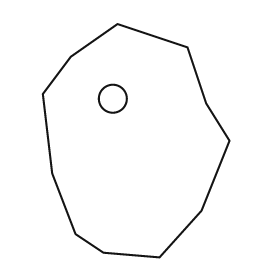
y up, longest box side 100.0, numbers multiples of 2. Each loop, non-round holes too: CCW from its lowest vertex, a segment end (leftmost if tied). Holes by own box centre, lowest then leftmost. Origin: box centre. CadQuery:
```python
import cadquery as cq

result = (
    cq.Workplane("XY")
    .moveTo(10.0, -50.0)
    .lineTo(28.0, -30.0)
    .lineTo(40.0, 0.0)
    .lineTo(30.0, 16.0)
    .lineTo(22.0, 40.0)
    .lineTo(-8.0, 50.0)
    .lineTo(-28.0, 36.0)
    .lineTo(-40.0, 20.0)
    .lineTo(-36.0, -14.0)
    .lineTo(-26.0, -40.0)
    .lineTo(-14.0, -48.0)
    .close()
    .moveTo(-10.0, 18.0)
    .circle(6.0)
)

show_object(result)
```